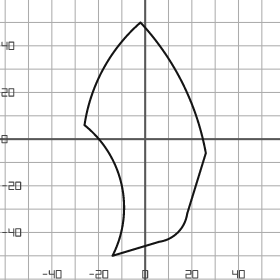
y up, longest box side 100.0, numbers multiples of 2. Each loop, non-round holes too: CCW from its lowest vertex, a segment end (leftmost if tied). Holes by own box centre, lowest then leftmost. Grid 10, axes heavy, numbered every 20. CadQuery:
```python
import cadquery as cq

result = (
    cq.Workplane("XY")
    .moveTo(-14.0, -50.0)
    .lineTo(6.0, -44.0)
    .threePointArc((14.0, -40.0), (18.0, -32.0))
    .lineTo(26.0, -6.0)
    .threePointArc((16.0, 24.0), (-2.0, 50.0))
    .threePointArc((-18.0, 30.0), (-26.0, 6.0))
    .threePointArc((-10.0, -20.0), (-14.0, -50.0))
    .close()
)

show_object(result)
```